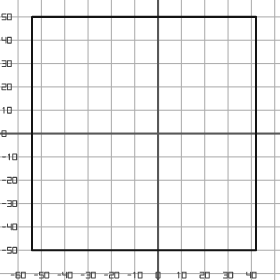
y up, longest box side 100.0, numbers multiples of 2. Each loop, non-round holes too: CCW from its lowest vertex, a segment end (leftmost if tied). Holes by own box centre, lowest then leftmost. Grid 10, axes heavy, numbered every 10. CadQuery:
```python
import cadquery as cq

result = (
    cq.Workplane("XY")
    .moveTo(-54.0, -50.0)
    .lineTo(42.0, -50.0)
    .lineTo(42.0, 50.0)
    .lineTo(-54.0, 50.0)
    .close()
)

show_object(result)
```